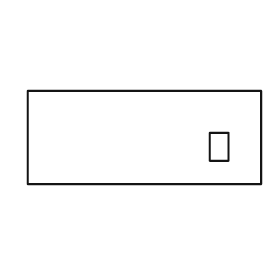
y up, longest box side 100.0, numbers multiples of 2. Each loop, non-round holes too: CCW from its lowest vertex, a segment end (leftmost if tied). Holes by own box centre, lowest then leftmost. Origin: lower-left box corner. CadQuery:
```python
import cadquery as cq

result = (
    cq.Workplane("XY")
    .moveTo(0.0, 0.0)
    .lineTo(100.0, 0.0)
    .lineTo(100.0, 40.0)
    .lineTo(0.0, 40.0)
    .close()
    .moveTo(78.0, 10.0)
    .lineTo(86.0, 10.0)
    .lineTo(86.0, 22.0)
    .lineTo(78.0, 22.0)
    .close()
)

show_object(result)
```